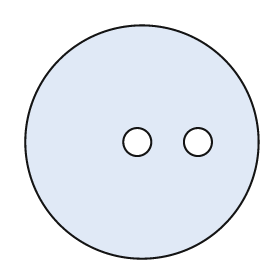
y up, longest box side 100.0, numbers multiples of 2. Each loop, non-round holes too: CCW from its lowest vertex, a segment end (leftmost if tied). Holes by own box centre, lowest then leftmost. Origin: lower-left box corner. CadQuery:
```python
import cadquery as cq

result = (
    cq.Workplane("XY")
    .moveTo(50.0, 50.0)
    .circle(50.0)
    .moveTo(48.0, 50.0)
    .circle(6.0)
    .moveTo(74.0, 50.0)
    .circle(6.0)
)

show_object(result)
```